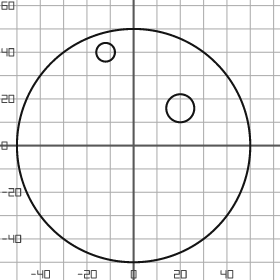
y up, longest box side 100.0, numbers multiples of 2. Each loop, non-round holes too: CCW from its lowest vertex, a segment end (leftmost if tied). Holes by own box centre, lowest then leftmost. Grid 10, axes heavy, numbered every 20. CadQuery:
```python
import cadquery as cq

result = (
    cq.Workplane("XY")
    .moveTo(0.0, 0.0)
    .circle(50.0)
    .moveTo(20.0, 16.0)
    .circle(6.0)
    .moveTo(-12.0, 40.0)
    .circle(4.0)
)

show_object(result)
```